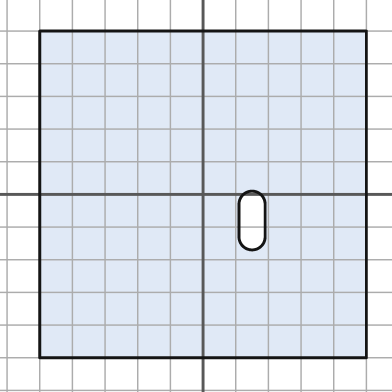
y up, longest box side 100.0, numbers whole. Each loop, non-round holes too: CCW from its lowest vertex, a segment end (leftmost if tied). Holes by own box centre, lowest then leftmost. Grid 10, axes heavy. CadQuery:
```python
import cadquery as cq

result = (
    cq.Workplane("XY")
    .moveTo(-50.0, -50.0)
    .lineTo(50.0, -50.0)
    .lineTo(50.0, 50.0)
    .lineTo(-50.0, 50.0)
    .close()
    .moveTo(11.0, -13.0)
    .threePointArc((15.0, -17.0), (19.0, -13.0))
    .lineTo(19.0, -3.0)
    .threePointArc((15.0, 1.0), (11.0, -3.0))
    .close()
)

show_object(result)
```